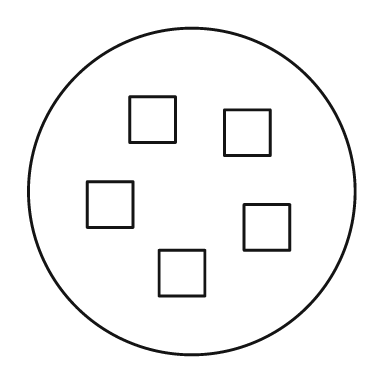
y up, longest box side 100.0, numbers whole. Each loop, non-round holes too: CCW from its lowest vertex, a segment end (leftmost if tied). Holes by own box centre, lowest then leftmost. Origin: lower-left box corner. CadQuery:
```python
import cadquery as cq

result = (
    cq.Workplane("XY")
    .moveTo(50.0, 50.0)
    .circle(50.0)
    .moveTo(40.0, 18.0)
    .lineTo(54.0, 18.0)
    .lineTo(54.0, 32.0)
    .lineTo(40.0, 32.0)
    .close()
    .moveTo(66.0, 32.0)
    .lineTo(80.0, 32.0)
    .lineTo(80.0, 46.0)
    .lineTo(66.0, 46.0)
    .close()
    .moveTo(18.0, 39.0)
    .lineTo(32.0, 39.0)
    .lineTo(32.0, 53.0)
    .lineTo(18.0, 53.0)
    .close()
    .moveTo(60.0, 61.0)
    .lineTo(74.0, 61.0)
    .lineTo(74.0, 75.0)
    .lineTo(60.0, 75.0)
    .close()
    .moveTo(31.0, 65.0)
    .lineTo(45.0, 65.0)
    .lineTo(45.0, 79.0)
    .lineTo(31.0, 79.0)
    .close()
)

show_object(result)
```